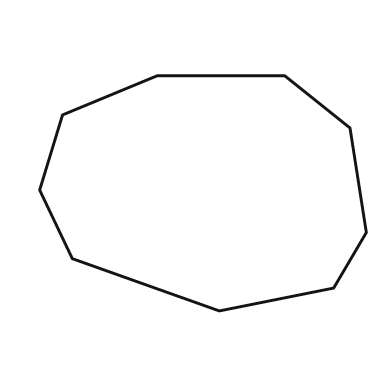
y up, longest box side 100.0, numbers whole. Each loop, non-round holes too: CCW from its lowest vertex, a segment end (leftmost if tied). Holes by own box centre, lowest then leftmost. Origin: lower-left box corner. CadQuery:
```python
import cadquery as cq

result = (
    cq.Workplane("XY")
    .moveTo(55.0, 0.0)
    .lineTo(90.0, 7.0)
    .lineTo(100.0, 24.0)
    .lineTo(95.0, 56.0)
    .lineTo(75.0, 72.0)
    .lineTo(36.0, 72.0)
    .lineTo(7.0, 60.0)
    .lineTo(0.0, 37.0)
    .lineTo(10.0, 16.0)
    .close()
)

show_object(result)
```